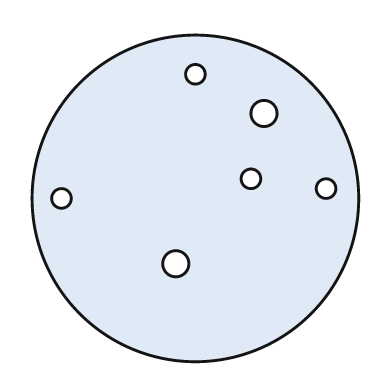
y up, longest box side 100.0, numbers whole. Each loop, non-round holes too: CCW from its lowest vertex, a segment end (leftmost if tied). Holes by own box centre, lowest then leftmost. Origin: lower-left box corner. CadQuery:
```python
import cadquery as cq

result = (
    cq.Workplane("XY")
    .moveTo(50.0, 50.0)
    .circle(50.0)
    .moveTo(44.0, 30.0)
    .circle(4.0)
    .moveTo(9.0, 50.0)
    .circle(3.0)
    .moveTo(90.0, 53.0)
    .circle(3.0)
    .moveTo(67.0, 56.0)
    .circle(3.0)
    .moveTo(71.0, 76.0)
    .circle(4.0)
    .moveTo(50.0, 88.0)
    .circle(3.0)
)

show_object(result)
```